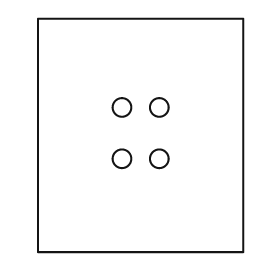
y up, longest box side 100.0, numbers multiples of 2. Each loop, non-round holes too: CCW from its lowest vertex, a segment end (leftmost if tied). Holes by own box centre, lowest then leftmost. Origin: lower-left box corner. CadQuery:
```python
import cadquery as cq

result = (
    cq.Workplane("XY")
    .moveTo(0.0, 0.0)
    .lineTo(88.0, 0.0)
    .lineTo(88.0, 100.0)
    .lineTo(0.0, 100.0)
    .close()
    .moveTo(36.0, 40.0)
    .circle(4.0)
    .moveTo(52.0, 40.0)
    .circle(4.0)
    .moveTo(36.0, 62.0)
    .circle(4.0)
    .moveTo(52.0, 62.0)
    .circle(4.0)
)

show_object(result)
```